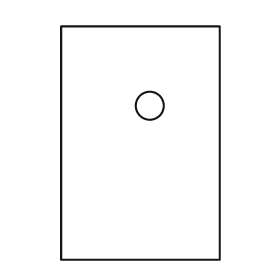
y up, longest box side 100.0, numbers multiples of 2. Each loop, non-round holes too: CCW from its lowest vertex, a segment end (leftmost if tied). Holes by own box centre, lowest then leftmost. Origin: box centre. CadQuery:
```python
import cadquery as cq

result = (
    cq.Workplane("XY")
    .moveTo(-34.0, -50.0)
    .lineTo(34.0, -50.0)
    .lineTo(34.0, 50.0)
    .lineTo(-34.0, 50.0)
    .close()
    .moveTo(4.0, 16.0)
    .circle(6.0)
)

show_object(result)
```